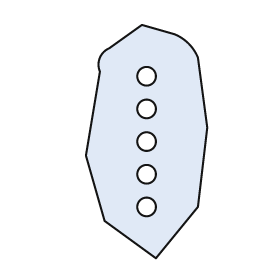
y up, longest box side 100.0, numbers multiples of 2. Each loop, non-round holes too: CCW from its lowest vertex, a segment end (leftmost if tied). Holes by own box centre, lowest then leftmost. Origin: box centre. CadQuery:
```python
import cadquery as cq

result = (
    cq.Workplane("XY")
    .moveTo(4.0, -50.0)
    .lineTo(22.0, -28.0)
    .lineTo(26.0, 6.0)
    .lineTo(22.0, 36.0)
    .threePointArc((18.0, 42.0), (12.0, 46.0))
    .lineTo(-2.0, 50.0)
    .lineTo(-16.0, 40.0)
    .threePointArc((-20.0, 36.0), (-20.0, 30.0))
    .lineTo(-26.0, -6.0)
    .lineTo(-18.0, -34.0)
    .close()
    .moveTo(0.0, -28.0)
    .circle(4.0)
    .moveTo(0.0, -14.0)
    .circle(4.0)
    .moveTo(0.0, 0.0)
    .circle(4.0)
    .moveTo(0.0, 14.0)
    .circle(4.0)
    .moveTo(0.0, 28.0)
    .circle(4.0)
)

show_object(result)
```